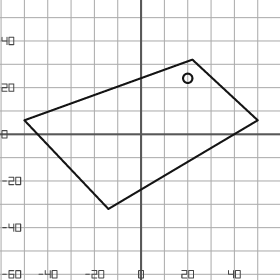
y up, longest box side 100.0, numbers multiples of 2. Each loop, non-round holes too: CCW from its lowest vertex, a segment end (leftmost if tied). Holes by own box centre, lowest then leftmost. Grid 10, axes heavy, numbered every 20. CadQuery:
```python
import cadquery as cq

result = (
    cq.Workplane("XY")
    .moveTo(-14.0, -32.0)
    .lineTo(50.0, 6.0)
    .lineTo(22.0, 32.0)
    .lineTo(-50.0, 6.0)
    .close()
    .moveTo(20.0, 24.0)
    .circle(2.0)
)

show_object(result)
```